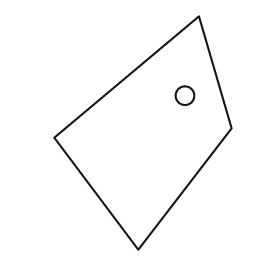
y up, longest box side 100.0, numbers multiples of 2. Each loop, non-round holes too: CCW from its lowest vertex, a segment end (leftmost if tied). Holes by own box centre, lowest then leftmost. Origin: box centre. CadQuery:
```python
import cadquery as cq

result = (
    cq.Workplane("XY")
    .moveTo(-2.0, -50.0)
    .lineTo(38.0, 2.0)
    .lineTo(24.0, 50.0)
    .lineTo(-38.0, -2.0)
    .close()
    .moveTo(18.0, 16.0)
    .circle(4.0)
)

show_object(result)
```